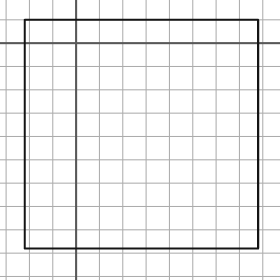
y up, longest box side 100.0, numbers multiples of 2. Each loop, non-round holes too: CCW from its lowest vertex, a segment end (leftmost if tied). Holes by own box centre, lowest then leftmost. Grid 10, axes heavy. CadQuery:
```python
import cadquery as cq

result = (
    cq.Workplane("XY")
    .moveTo(-22.0, -88.0)
    .lineTo(78.0, -88.0)
    .lineTo(78.0, 10.0)
    .lineTo(-22.0, 10.0)
    .close()
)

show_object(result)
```